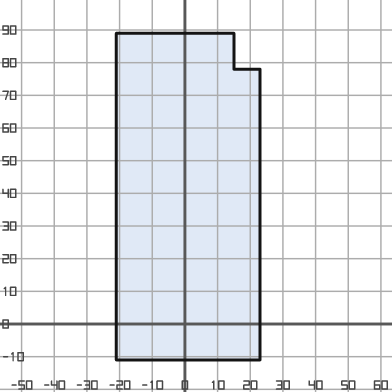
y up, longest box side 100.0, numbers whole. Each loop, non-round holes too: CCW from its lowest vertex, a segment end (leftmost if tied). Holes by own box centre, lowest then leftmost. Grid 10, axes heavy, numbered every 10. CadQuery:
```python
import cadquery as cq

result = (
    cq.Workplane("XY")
    .moveTo(-21.0, -11.0)
    .lineTo(23.0, -11.0)
    .lineTo(23.0, 78.0)
    .lineTo(15.0, 78.0)
    .lineTo(15.0, 89.0)
    .lineTo(-21.0, 89.0)
    .close()
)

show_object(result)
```